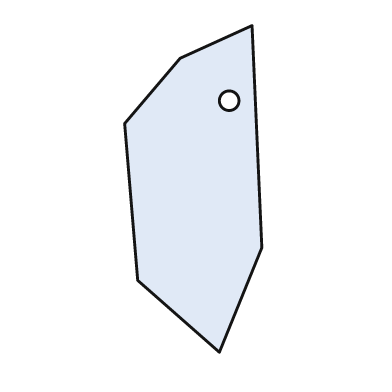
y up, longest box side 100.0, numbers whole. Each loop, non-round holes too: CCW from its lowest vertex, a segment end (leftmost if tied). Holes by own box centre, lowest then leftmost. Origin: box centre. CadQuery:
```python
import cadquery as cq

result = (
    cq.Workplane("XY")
    .moveTo(8.0, -50.0)
    .lineTo(21.0, -18.0)
    .lineTo(18.0, 50.0)
    .lineTo(-4.0, 40.0)
    .lineTo(-21.0, 20.0)
    .lineTo(-17.0, -28.0)
    .close()
    .moveTo(11.0, 27.0)
    .circle(3.0)
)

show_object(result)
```